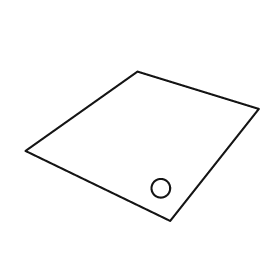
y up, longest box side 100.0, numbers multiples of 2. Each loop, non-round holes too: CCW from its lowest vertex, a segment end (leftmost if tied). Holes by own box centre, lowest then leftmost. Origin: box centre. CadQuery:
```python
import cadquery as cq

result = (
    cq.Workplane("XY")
    .moveTo(12.0, -32.0)
    .lineTo(50.0, 16.0)
    .lineTo(-2.0, 32.0)
    .lineTo(-50.0, -2.0)
    .close()
    .moveTo(8.0, -18.0)
    .circle(4.0)
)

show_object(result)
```